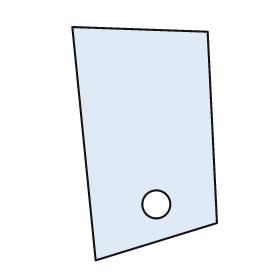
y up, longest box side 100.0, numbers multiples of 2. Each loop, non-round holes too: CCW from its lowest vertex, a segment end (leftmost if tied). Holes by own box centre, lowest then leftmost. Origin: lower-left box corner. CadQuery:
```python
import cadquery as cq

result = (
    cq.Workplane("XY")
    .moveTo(10.0, 0.0)
    .lineTo(62.0, 16.0)
    .lineTo(58.0, 98.0)
    .lineTo(0.0, 100.0)
    .close()
    .moveTo(36.0, 24.0)
    .circle(6.0)
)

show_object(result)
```